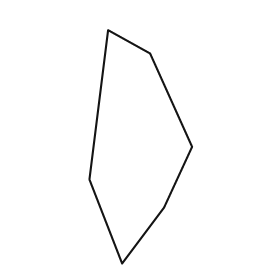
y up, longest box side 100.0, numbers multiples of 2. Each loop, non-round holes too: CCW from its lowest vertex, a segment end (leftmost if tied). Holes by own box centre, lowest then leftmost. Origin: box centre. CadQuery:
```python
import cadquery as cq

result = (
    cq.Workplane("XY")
    .moveTo(-8.0, -50.0)
    .lineTo(10.0, -26.0)
    .lineTo(22.0, 0.0)
    .lineTo(4.0, 40.0)
    .lineTo(-14.0, 50.0)
    .lineTo(-22.0, -14.0)
    .close()
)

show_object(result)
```